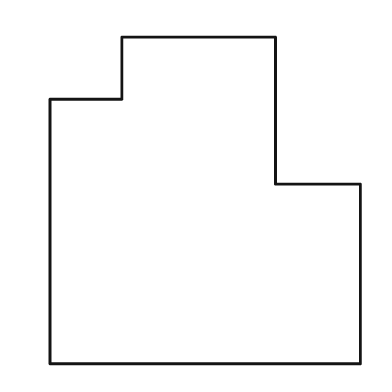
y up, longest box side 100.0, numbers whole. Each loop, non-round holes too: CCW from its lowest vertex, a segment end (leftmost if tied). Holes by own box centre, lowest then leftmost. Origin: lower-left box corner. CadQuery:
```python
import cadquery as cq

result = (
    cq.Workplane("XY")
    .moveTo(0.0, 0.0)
    .lineTo(95.0, 0.0)
    .lineTo(95.0, 55.0)
    .lineTo(69.0, 55.0)
    .lineTo(69.0, 100.0)
    .lineTo(22.0, 100.0)
    .lineTo(22.0, 81.0)
    .lineTo(0.0, 81.0)
    .close()
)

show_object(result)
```